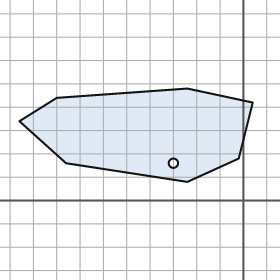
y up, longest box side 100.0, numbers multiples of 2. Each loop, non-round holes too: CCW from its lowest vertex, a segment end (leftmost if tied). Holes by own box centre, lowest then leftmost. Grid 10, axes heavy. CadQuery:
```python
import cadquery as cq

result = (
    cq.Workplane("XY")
    .moveTo(-24.0, 8.0)
    .lineTo(-2.0, 18.0)
    .lineTo(4.0, 42.0)
    .lineTo(-24.0, 48.0)
    .lineTo(-80.0, 44.0)
    .lineTo(-96.0, 34.0)
    .lineTo(-76.0, 16.0)
    .close()
    .moveTo(-30.0, 16.0)
    .circle(2.0)
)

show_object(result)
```